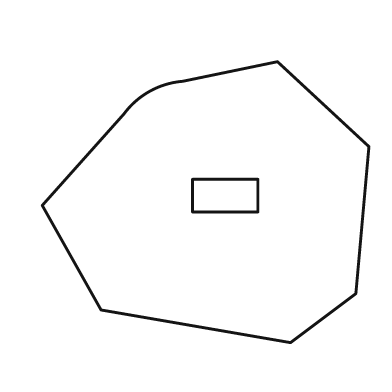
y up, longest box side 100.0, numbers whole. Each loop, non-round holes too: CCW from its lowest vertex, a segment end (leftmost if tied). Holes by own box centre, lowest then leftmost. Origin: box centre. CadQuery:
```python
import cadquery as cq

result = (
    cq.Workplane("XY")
    .moveTo(26.0, -43.0)
    .lineTo(46.0, -28.0)
    .lineTo(50.0, 17.0)
    .lineTo(22.0, 43.0)
    .lineTo(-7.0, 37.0)
    .threePointArc((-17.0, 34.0), (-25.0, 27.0))
    .lineTo(-50.0, -1.0)
    .lineTo(-32.0, -33.0)
    .close()
    .moveTo(-4.0, -3.0)
    .lineTo(16.0, -3.0)
    .lineTo(16.0, 7.0)
    .lineTo(-4.0, 7.0)
    .close()
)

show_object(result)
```